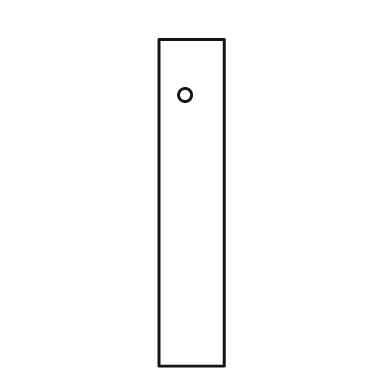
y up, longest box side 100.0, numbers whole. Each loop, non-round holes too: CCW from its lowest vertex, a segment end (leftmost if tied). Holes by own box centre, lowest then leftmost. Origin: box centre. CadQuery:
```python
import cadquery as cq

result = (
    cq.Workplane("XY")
    .moveTo(-10.0, -50.0)
    .lineTo(10.0, -50.0)
    .lineTo(10.0, 50.0)
    .lineTo(-10.0, 50.0)
    .close()
    .moveTo(-2.0, 33.0)
    .circle(2.0)
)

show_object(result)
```